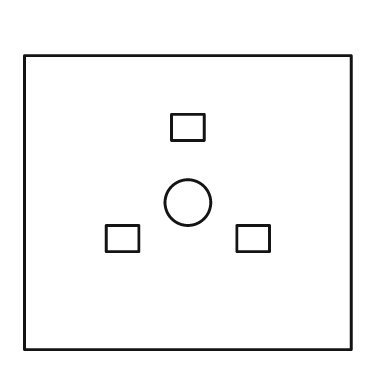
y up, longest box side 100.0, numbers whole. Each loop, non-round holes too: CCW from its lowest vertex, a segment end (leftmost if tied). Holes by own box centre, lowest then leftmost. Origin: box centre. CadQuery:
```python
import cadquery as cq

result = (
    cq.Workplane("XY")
    .moveTo(-50.0, -45.0)
    .lineTo(50.0, -45.0)
    .lineTo(50.0, 45.0)
    .lineTo(-50.0, 45.0)
    .close()
    .moveTo(-25.0, -15.0)
    .lineTo(-15.0, -15.0)
    .lineTo(-15.0, -7.0)
    .lineTo(-25.0, -7.0)
    .close()
    .moveTo(15.0, -15.0)
    .lineTo(25.0, -15.0)
    .lineTo(25.0, -7.0)
    .lineTo(15.0, -7.0)
    .close()
    .moveTo(0.0, 0.0)
    .circle(7.0)
    .moveTo(-5.0, 19.0)
    .lineTo(5.0, 19.0)
    .lineTo(5.0, 27.0)
    .lineTo(-5.0, 27.0)
    .close()
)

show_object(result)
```